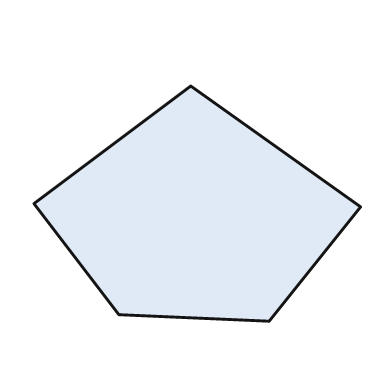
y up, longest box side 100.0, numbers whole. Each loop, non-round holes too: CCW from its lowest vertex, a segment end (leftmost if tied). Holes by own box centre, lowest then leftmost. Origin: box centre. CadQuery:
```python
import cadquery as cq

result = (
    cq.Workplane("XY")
    .moveTo(22.0, -36.0)
    .lineTo(50.0, -1.0)
    .lineTo(-2.0, 36.0)
    .lineTo(-50.0, 0.0)
    .lineTo(-24.0, -34.0)
    .close()
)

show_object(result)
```